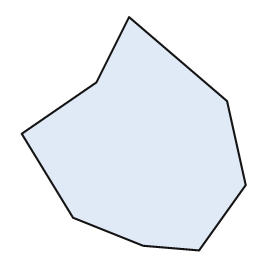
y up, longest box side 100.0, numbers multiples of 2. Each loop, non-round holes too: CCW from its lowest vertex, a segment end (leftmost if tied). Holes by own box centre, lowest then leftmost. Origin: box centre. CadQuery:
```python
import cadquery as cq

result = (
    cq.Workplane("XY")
    .moveTo(28.0, -50.0)
    .lineTo(48.0, -22.0)
    .lineTo(40.0, 14.0)
    .lineTo(-2.0, 50.0)
    .lineTo(-16.0, 22.0)
    .lineTo(-48.0, 0.0)
    .lineTo(-26.0, -36.0)
    .lineTo(4.0, -48.0)
    .close()
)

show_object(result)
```